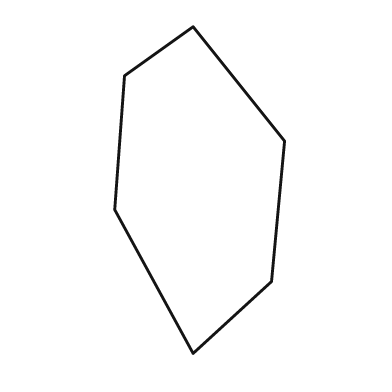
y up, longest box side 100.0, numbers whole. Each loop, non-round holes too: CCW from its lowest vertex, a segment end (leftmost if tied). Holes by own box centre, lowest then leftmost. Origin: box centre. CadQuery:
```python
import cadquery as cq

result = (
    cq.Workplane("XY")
    .moveTo(-2.0, -50.0)
    .lineTo(22.0, -28.0)
    .lineTo(26.0, 15.0)
    .lineTo(-2.0, 50.0)
    .lineTo(-23.0, 35.0)
    .lineTo(-26.0, -6.0)
    .close()
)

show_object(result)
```